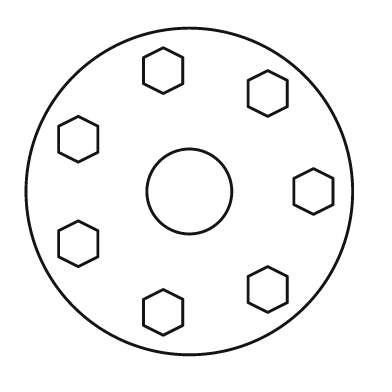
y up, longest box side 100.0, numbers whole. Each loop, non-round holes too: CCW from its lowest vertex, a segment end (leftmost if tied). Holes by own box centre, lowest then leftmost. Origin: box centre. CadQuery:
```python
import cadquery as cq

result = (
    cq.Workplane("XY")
    .moveTo(0.0, 0.0)
    .circle(50.0)
    .moveTo(-8.0, -44.0)
    .lineTo(-2.0, -41.0)
    .lineTo(-2.0, -33.0)
    .lineTo(-8.0, -30.0)
    .lineTo(-14.0, -33.0)
    .lineTo(-14.0, -41.0)
    .close()
    .moveTo(24.0, -37.0)
    .lineTo(30.0, -34.0)
    .lineTo(30.0, -26.0)
    .lineTo(24.0, -23.0)
    .lineTo(18.0, -26.0)
    .lineTo(18.0, -34.0)
    .close()
    .moveTo(-34.0, -23.0)
    .lineTo(-28.0, -20.0)
    .lineTo(-28.0, -12.0)
    .lineTo(-34.0, -9.0)
    .lineTo(-40.0, -12.0)
    .lineTo(-40.0, -20.0)
    .close()
    .moveTo(0.0, 0.0)
    .circle(13.0)
    .moveTo(38.0, -7.0)
    .lineTo(44.0, -4.0)
    .lineTo(44.0, 4.0)
    .lineTo(38.0, 7.0)
    .lineTo(32.0, 4.0)
    .lineTo(32.0, -4.0)
    .close()
    .moveTo(-34.0, 9.0)
    .lineTo(-28.0, 12.0)
    .lineTo(-28.0, 20.0)
    .lineTo(-34.0, 23.0)
    .lineTo(-40.0, 20.0)
    .lineTo(-40.0, 12.0)
    .close()
    .moveTo(24.0, 23.0)
    .lineTo(30.0, 26.0)
    .lineTo(30.0, 34.0)
    .lineTo(24.0, 37.0)
    .lineTo(18.0, 34.0)
    .lineTo(18.0, 26.0)
    .close()
    .moveTo(-8.0, 30.0)
    .lineTo(-2.0, 33.0)
    .lineTo(-2.0, 41.0)
    .lineTo(-8.0, 44.0)
    .lineTo(-14.0, 41.0)
    .lineTo(-14.0, 33.0)
    .close()
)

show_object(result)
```